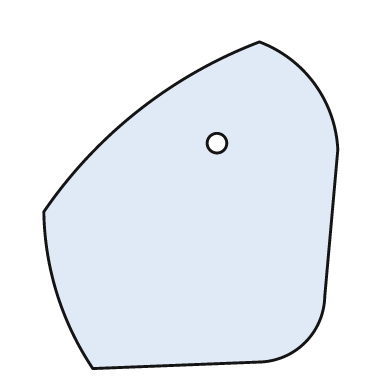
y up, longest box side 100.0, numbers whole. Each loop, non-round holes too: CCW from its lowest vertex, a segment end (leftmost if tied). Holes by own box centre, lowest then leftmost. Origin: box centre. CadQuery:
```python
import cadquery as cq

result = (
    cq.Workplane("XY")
    .moveTo(-30.0, -50.0)
    .lineTo(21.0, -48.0)
    .threePointArc((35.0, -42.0), (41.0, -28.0))
    .lineTo(45.0, 17.0)
    .threePointArc((38.0, 37.0), (21.0, 50.0))
    .threePointArc((-16.0, 29.0), (-45.0, -2.0))
    .threePointArc((-41.0, -27.0), (-30.0, -50.0))
    .close()
    .moveTo(8.0, 19.0)
    .circle(3.0)
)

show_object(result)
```